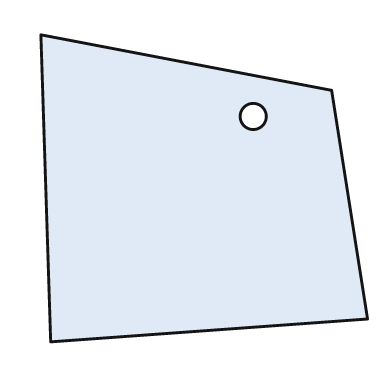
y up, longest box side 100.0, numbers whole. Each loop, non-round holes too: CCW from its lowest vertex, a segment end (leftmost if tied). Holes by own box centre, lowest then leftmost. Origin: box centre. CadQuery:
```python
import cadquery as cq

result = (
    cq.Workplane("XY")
    .moveTo(-47.0, -47.0)
    .lineTo(50.0, -40.0)
    .lineTo(39.0, 30.0)
    .lineTo(-50.0, 47.0)
    .close()
    .moveTo(15.0, 22.0)
    .circle(4.0)
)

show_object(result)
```